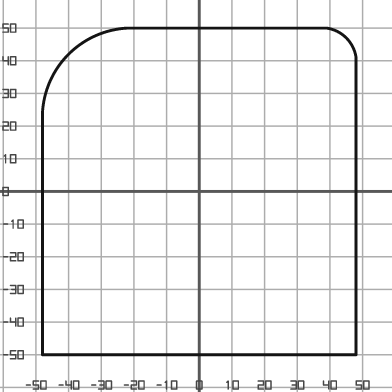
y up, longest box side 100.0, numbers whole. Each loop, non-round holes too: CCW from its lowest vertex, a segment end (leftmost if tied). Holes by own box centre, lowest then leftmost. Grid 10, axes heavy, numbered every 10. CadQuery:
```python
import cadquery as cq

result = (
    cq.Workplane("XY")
    .moveTo(-48.0, -50.0)
    .lineTo(48.0, -50.0)
    .lineTo(48.0, 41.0)
    .threePointArc((45.0, 47.0), (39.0, 50.0))
    .lineTo(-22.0, 50.0)
    .threePointArc((-40.0, 42.0), (-48.0, 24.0))
    .close()
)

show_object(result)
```